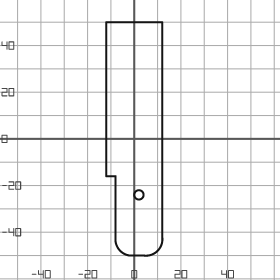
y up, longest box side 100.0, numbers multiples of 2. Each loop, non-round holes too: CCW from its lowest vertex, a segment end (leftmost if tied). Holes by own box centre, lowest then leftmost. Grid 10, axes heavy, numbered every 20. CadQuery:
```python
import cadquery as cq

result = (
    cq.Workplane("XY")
    .moveTo(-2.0, -50.0)
    .lineTo(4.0, -50.0)
    .threePointArc((10.0, -48.0), (12.0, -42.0))
    .lineTo(12.0, 50.0)
    .lineTo(-12.0, 50.0)
    .lineTo(-12.0, -16.0)
    .lineTo(-8.0, -16.0)
    .lineTo(-8.0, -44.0)
    .threePointArc((-6.0, -48.0), (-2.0, -50.0))
    .close()
    .moveTo(2.0, -24.0)
    .circle(2.0)
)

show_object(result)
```